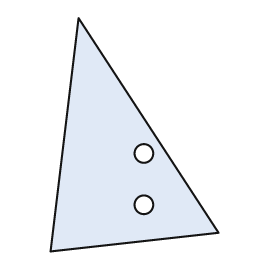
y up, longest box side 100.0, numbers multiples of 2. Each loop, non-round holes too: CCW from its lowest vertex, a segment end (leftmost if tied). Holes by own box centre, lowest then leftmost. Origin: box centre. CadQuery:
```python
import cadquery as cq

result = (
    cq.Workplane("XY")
    .moveTo(-36.0, -50.0)
    .lineTo(36.0, -42.0)
    .lineTo(-24.0, 50.0)
    .close()
    .moveTo(4.0, -30.0)
    .circle(4.0)
    .moveTo(4.0, -8.0)
    .circle(4.0)
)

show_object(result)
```